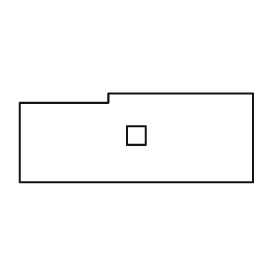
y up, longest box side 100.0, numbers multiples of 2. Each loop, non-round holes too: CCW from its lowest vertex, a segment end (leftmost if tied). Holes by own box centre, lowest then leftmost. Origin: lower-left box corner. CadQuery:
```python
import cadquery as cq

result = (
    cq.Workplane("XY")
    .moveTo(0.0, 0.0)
    .lineTo(100.0, 0.0)
    .lineTo(100.0, 38.0)
    .lineTo(38.0, 38.0)
    .lineTo(38.0, 34.0)
    .lineTo(0.0, 34.0)
    .close()
    .moveTo(46.0, 16.0)
    .lineTo(54.0, 16.0)
    .lineTo(54.0, 24.0)
    .lineTo(46.0, 24.0)
    .close()
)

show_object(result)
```